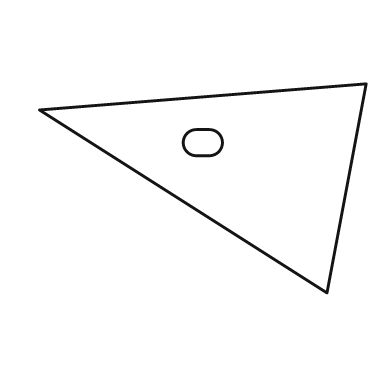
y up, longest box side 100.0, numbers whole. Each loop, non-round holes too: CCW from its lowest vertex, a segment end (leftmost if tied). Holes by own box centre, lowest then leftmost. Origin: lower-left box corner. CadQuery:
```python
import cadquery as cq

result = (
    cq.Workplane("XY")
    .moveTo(88.0, 0.0)
    .lineTo(100.0, 64.0)
    .lineTo(0.0, 56.0)
    .close()
    .moveTo(48.0, 42.0)
    .lineTo(52.0, 42.0)
    .threePointArc((56.0, 46.0), (52.0, 50.0))
    .lineTo(48.0, 50.0)
    .threePointArc((44.0, 46.0), (48.0, 42.0))
    .close()
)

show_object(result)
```